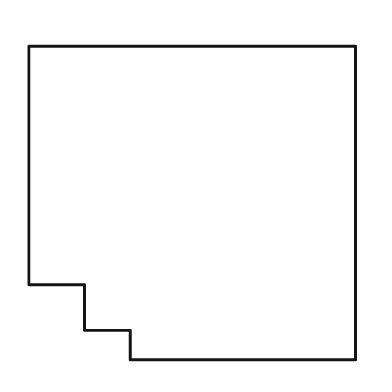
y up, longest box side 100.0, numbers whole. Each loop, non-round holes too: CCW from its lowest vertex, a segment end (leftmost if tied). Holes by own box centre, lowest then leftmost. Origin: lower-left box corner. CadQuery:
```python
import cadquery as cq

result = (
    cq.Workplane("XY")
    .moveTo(31.0, 0.0)
    .lineTo(100.0, 0.0)
    .lineTo(100.0, 96.0)
    .lineTo(0.0, 96.0)
    .lineTo(0.0, 23.0)
    .lineTo(17.0, 23.0)
    .lineTo(17.0, 9.0)
    .lineTo(31.0, 9.0)
    .close()
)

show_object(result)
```